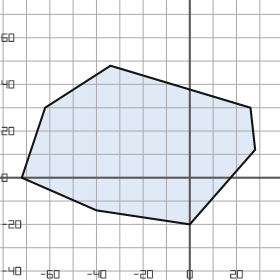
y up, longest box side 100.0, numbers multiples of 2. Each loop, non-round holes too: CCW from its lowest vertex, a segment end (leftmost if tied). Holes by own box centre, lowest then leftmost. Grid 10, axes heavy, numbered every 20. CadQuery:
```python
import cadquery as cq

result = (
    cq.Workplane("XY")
    .moveTo(0.0, -20.0)
    .lineTo(28.0, 12.0)
    .lineTo(26.0, 30.0)
    .lineTo(-34.0, 48.0)
    .lineTo(-62.0, 30.0)
    .lineTo(-72.0, 0.0)
    .lineTo(-40.0, -14.0)
    .close()
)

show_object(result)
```